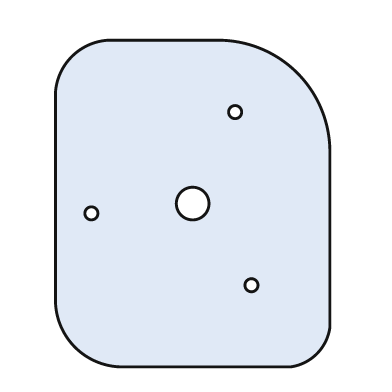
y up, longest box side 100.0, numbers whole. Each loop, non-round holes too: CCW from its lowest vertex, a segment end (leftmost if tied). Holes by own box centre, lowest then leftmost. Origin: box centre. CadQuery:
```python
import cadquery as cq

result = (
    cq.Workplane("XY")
    .moveTo(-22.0, -50.0)
    .lineTo(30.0, -50.0)
    .threePointArc((38.0, -46.0), (42.0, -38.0))
    .lineTo(42.0, 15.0)
    .threePointArc((32.0, 40.0), (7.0, 50.0))
    .lineTo(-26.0, 50.0)
    .threePointArc((-37.0, 45.0), (-42.0, 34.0))
    .lineTo(-42.0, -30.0)
    .threePointArc((-36.0, -44.0), (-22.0, -50.0))
    .close()
    .moveTo(18.0, -25.0)
    .circle(2.0)
    .moveTo(-31.0, -3.0)
    .circle(2.0)
    .moveTo(0.0, 0.0)
    .circle(5.0)
    .moveTo(13.0, 28.0)
    .circle(2.0)
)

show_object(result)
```